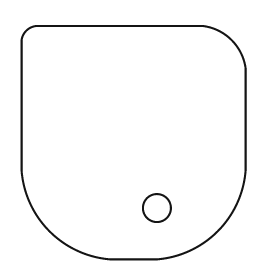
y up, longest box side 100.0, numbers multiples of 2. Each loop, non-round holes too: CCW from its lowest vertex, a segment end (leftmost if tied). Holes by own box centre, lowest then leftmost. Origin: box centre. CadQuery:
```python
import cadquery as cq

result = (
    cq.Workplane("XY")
    .moveTo(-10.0, -50.0)
    .lineTo(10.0, -50.0)
    .threePointArc((36.0, -38.0), (48.0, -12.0))
    .lineTo(48.0, 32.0)
    .threePointArc((42.0, 44.0), (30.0, 50.0))
    .lineTo(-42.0, 50.0)
    .threePointArc((-46.0, 48.0), (-48.0, 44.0))
    .lineTo(-48.0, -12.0)
    .threePointArc((-36.0, -38.0), (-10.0, -50.0))
    .close()
    .moveTo(10.0, -28.0)
    .circle(6.0)
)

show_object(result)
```